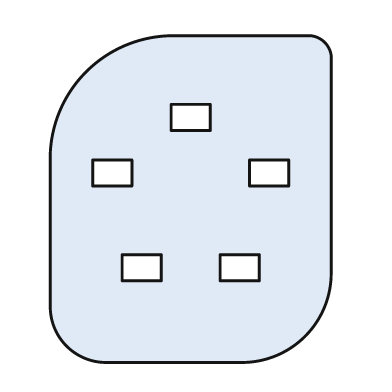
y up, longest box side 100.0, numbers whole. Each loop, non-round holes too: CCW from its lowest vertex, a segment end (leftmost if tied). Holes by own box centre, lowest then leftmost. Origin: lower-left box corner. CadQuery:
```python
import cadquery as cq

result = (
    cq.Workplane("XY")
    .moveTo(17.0, 0.0)
    .lineTo(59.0, 0.0)
    .threePointArc((78.0, 8.0), (86.0, 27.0))
    .lineTo(86.0, 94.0)
    .threePointArc((84.0, 98.0), (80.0, 100.0))
    .lineTo(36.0, 100.0)
    .threePointArc((11.0, 89.0), (0.0, 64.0))
    .lineTo(0.0, 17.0)
    .threePointArc((5.0, 5.0), (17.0, 0.0))
    .close()
    .moveTo(22.0, 25.0)
    .lineTo(34.0, 25.0)
    .lineTo(34.0, 33.0)
    .lineTo(22.0, 33.0)
    .close()
    .moveTo(52.0, 25.0)
    .lineTo(64.0, 25.0)
    .lineTo(64.0, 33.0)
    .lineTo(52.0, 33.0)
    .close()
    .moveTo(13.0, 54.0)
    .lineTo(25.0, 54.0)
    .lineTo(25.0, 62.0)
    .lineTo(13.0, 62.0)
    .close()
    .moveTo(61.0, 54.0)
    .lineTo(73.0, 54.0)
    .lineTo(73.0, 62.0)
    .lineTo(61.0, 62.0)
    .close()
    .moveTo(37.0, 71.0)
    .lineTo(49.0, 71.0)
    .lineTo(49.0, 79.0)
    .lineTo(37.0, 79.0)
    .close()
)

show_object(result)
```